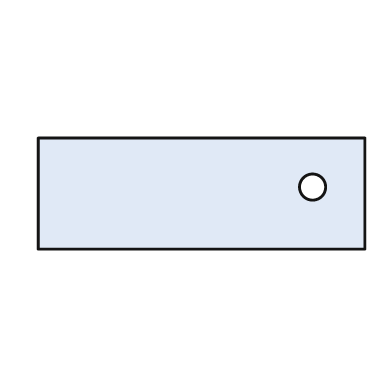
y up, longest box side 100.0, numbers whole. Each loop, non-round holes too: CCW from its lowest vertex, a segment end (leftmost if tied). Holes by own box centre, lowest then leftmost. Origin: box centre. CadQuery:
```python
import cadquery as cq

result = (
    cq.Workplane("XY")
    .moveTo(-50.0, -17.0)
    .lineTo(50.0, -17.0)
    .lineTo(50.0, 17.0)
    .lineTo(-50.0, 17.0)
    .close()
    .moveTo(34.0, 2.0)
    .circle(4.0)
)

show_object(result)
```